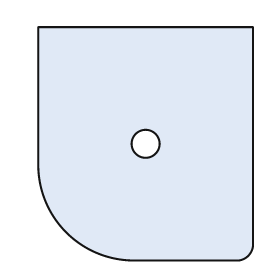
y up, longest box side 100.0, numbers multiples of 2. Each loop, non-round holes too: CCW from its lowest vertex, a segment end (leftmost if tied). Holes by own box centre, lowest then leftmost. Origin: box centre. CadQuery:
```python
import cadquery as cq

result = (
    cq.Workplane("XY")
    .moveTo(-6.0, -50.0)
    .lineTo(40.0, -50.0)
    .threePointArc((44.0, -48.0), (46.0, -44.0))
    .lineTo(46.0, 50.0)
    .lineTo(-46.0, 50.0)
    .lineTo(-46.0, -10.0)
    .threePointArc((-34.0, -38.0), (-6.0, -50.0))
    .close()
    .moveTo(0.0, 0.0)
    .circle(6.0)
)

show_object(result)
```